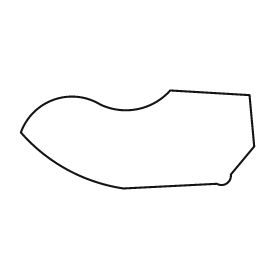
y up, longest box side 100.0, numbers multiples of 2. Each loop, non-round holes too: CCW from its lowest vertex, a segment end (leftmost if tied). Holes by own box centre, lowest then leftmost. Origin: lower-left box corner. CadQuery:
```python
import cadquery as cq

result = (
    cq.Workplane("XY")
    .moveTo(44.0, 0.0)
    .lineTo(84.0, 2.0)
    .threePointArc((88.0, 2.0), (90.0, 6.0))
    .lineTo(100.0, 18.0)
    .lineTo(98.0, 40.0)
    .lineTo(64.0, 42.0)
    .threePointArc((50.0, 34.0), (34.0, 36.0))
    .threePointArc((14.0, 38.0), (0.0, 24.0))
    .threePointArc((20.0, 8.0), (44.0, 0.0))
    .close()
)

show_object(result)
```